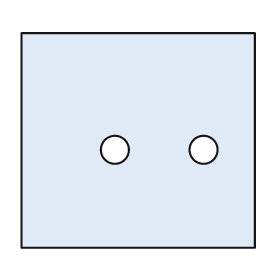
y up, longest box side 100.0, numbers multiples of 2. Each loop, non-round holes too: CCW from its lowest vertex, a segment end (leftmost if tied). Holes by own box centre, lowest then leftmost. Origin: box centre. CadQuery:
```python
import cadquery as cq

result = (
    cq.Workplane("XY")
    .moveTo(-50.0, -46.0)
    .lineTo(50.0, -46.0)
    .lineTo(50.0, 46.0)
    .lineTo(-50.0, 46.0)
    .close()
    .moveTo(-10.0, -4.0)
    .circle(6.0)
    .moveTo(28.0, -4.0)
    .circle(6.0)
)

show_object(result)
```